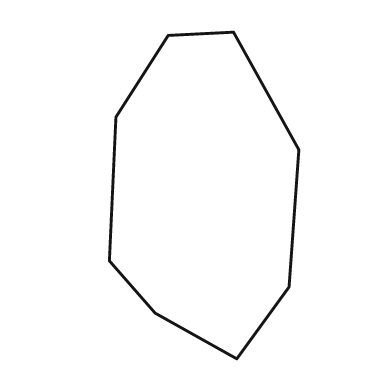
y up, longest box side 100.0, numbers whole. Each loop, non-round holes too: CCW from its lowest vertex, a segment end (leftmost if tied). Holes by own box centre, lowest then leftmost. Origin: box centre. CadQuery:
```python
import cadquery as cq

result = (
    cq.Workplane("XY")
    .moveTo(10.0, -50.0)
    .lineTo(26.0, -28.0)
    .lineTo(29.0, 14.0)
    .lineTo(9.0, 50.0)
    .lineTo(-11.0, 49.0)
    .lineTo(-27.0, 24.0)
    .lineTo(-29.0, -20.0)
    .lineTo(-15.0, -36.0)
    .close()
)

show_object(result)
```